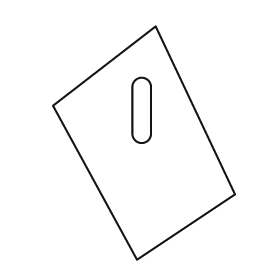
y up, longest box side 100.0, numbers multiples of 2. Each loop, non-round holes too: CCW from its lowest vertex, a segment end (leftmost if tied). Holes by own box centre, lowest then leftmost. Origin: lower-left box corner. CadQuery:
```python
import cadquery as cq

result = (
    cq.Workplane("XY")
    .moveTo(36.0, 0.0)
    .lineTo(78.0, 28.0)
    .lineTo(44.0, 100.0)
    .lineTo(0.0, 66.0)
    .close()
    .moveTo(34.0, 54.0)
    .threePointArc((38.0, 50.0), (42.0, 54.0))
    .lineTo(42.0, 74.0)
    .threePointArc((38.0, 78.0), (34.0, 74.0))
    .close()
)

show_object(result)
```